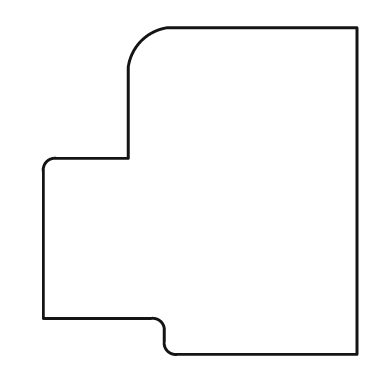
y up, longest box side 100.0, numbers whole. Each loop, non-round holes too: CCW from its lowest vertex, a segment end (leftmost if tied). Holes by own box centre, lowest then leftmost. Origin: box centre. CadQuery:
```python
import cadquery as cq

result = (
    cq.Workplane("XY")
    .moveTo(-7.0, -50.0)
    .lineTo(48.0, -50.0)
    .lineTo(48.0, 50.0)
    .lineTo(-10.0, 50.0)
    .threePointArc((-18.0, 46.0), (-22.0, 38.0))
    .lineTo(-22.0, 10.0)
    .lineTo(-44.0, 10.0)
    .threePointArc((-47.0, 9.0), (-48.0, 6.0))
    .lineTo(-48.0, -39.0)
    .lineTo(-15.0, -39.0)
    .threePointArc((-12.0, -40.0), (-11.0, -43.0))
    .lineTo(-11.0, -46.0)
    .threePointArc((-10.0, -49.0), (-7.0, -50.0))
    .close()
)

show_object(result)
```